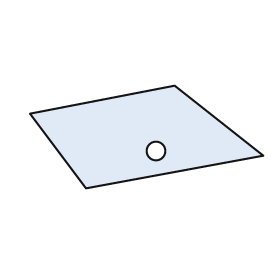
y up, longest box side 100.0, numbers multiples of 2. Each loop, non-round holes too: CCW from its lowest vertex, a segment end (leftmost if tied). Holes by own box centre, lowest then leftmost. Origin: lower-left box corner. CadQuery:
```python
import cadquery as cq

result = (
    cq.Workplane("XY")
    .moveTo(24.0, 0.0)
    .lineTo(100.0, 14.0)
    .lineTo(62.0, 44.0)
    .lineTo(0.0, 32.0)
    .close()
    .moveTo(54.0, 16.0)
    .circle(4.0)
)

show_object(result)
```